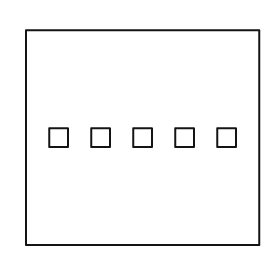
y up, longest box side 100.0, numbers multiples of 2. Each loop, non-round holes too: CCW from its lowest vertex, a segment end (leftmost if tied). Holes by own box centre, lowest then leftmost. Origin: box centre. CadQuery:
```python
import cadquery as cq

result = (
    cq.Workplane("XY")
    .moveTo(-50.0, -46.0)
    .lineTo(50.0, -46.0)
    .lineTo(50.0, 46.0)
    .lineTo(-50.0, 46.0)
    .close()
    .moveTo(-40.0, -4.0)
    .lineTo(-32.0, -4.0)
    .lineTo(-32.0, 4.0)
    .lineTo(-40.0, 4.0)
    .close()
    .moveTo(-22.0, -4.0)
    .lineTo(-14.0, -4.0)
    .lineTo(-14.0, 4.0)
    .lineTo(-22.0, 4.0)
    .close()
    .moveTo(-4.0, -4.0)
    .lineTo(4.0, -4.0)
    .lineTo(4.0, 4.0)
    .lineTo(-4.0, 4.0)
    .close()
    .moveTo(14.0, -4.0)
    .lineTo(22.0, -4.0)
    .lineTo(22.0, 4.0)
    .lineTo(14.0, 4.0)
    .close()
    .moveTo(32.0, -4.0)
    .lineTo(40.0, -4.0)
    .lineTo(40.0, 4.0)
    .lineTo(32.0, 4.0)
    .close()
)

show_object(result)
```